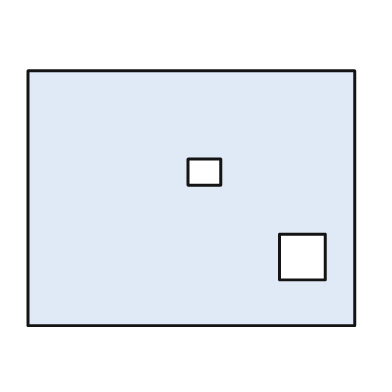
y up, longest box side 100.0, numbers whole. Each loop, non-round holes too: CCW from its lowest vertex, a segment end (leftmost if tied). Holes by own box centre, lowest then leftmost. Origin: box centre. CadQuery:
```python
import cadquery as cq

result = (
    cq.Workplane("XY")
    .moveTo(-50.0, -39.0)
    .lineTo(50.0, -39.0)
    .lineTo(50.0, 39.0)
    .lineTo(-50.0, 39.0)
    .close()
    .moveTo(27.0, -25.0)
    .lineTo(41.0, -25.0)
    .lineTo(41.0, -11.0)
    .lineTo(27.0, -11.0)
    .close()
    .moveTo(-1.0, 4.0)
    .lineTo(9.0, 4.0)
    .lineTo(9.0, 12.0)
    .lineTo(-1.0, 12.0)
    .close()
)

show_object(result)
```